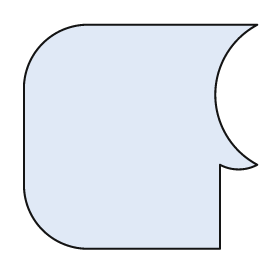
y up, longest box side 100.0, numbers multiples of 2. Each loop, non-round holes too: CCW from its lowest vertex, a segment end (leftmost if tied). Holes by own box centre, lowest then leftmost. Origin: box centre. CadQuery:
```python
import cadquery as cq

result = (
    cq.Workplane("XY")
    .moveTo(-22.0, -48.0)
    .lineTo(34.0, -48.0)
    .lineTo(34.0, -12.0)
    .threePointArc((42.0, -14.0), (50.0, -12.0))
    .threePointArc((32.0, 18.0), (50.0, 48.0))
    .lineTo(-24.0, 48.0)
    .threePointArc((-42.0, 40.0), (-50.0, 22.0))
    .lineTo(-50.0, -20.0)
    .threePointArc((-42.0, -40.0), (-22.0, -48.0))
    .close()
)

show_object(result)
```